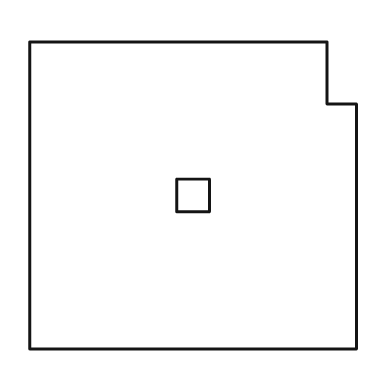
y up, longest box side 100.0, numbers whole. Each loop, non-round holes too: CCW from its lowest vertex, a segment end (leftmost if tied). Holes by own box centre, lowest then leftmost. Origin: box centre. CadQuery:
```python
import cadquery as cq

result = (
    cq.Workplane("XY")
    .moveTo(-50.0, -47.0)
    .lineTo(50.0, -47.0)
    .lineTo(50.0, 28.0)
    .lineTo(41.0, 28.0)
    .lineTo(41.0, 47.0)
    .lineTo(-50.0, 47.0)
    .close()
    .moveTo(-5.0, -5.0)
    .lineTo(5.0, -5.0)
    .lineTo(5.0, 5.0)
    .lineTo(-5.0, 5.0)
    .close()
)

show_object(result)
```